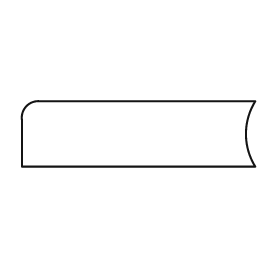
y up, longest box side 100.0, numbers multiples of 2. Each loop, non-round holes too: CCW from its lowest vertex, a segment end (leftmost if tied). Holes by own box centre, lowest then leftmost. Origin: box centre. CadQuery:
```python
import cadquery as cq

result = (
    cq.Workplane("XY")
    .moveTo(-50.0, -14.0)
    .lineTo(50.0, -14.0)
    .threePointArc((46.0, 0.0), (50.0, 14.0))
    .lineTo(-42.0, 14.0)
    .threePointArc((-48.0, 12.0), (-50.0, 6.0))
    .close()
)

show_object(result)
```